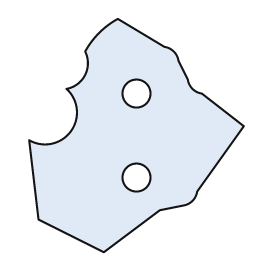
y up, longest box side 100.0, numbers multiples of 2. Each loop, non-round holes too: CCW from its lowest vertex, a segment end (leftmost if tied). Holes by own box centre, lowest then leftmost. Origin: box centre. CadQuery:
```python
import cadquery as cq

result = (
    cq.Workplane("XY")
    .moveTo(-14.0, -50.0)
    .lineTo(10.0, -32.0)
    .lineTo(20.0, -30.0)
    .threePointArc((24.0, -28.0), (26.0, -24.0))
    .lineTo(46.0, 4.0)
    .lineTo(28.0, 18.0)
    .threePointArc((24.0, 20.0), (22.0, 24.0))
    .lineTo(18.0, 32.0)
    .threePointArc((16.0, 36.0), (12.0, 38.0))
    .lineTo(-8.0, 50.0)
    .threePointArc((-16.0, 44.0), (-22.0, 36.0))
    .threePointArc((-22.0, 26.0), (-30.0, 20.0))
    .threePointArc((-28.0, 2.0), (-46.0, -2.0))
    .lineTo(-42.0, -36.0)
    .close()
    .moveTo(0.0, -18.0)
    .circle(6.0)
    .moveTo(0.0, 18.0)
    .circle(6.0)
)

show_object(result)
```